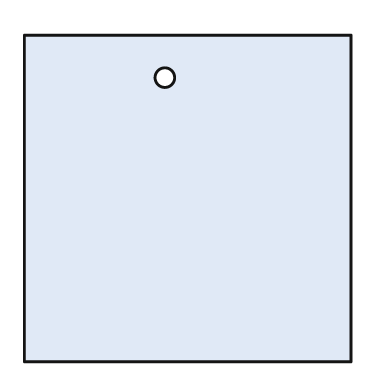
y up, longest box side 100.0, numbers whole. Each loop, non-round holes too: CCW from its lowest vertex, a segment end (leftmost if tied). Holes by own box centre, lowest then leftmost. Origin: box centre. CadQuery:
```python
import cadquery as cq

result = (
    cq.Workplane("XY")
    .moveTo(-50.0, -50.0)
    .lineTo(50.0, -50.0)
    .lineTo(50.0, 50.0)
    .lineTo(-50.0, 50.0)
    .close()
    .moveTo(-7.0, 37.0)
    .circle(3.0)
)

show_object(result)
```